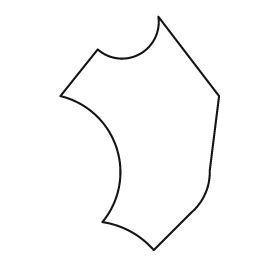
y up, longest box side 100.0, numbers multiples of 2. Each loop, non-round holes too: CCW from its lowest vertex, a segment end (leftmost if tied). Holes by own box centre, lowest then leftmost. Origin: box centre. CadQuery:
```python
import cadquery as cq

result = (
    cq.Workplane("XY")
    .moveTo(6.0, -50.0)
    .lineTo(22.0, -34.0)
    .threePointArc((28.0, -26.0), (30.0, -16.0))
    .lineTo(34.0, 16.0)
    .lineTo(8.0, 50.0)
    .threePointArc((0.0, 34.0), (-18.0, 36.0))
    .lineTo(-34.0, 16.0)
    .threePointArc((-10.0, -6.0), (-16.0, -38.0))
    .threePointArc((-4.0, -42.0), (6.0, -50.0))
    .close()
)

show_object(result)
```